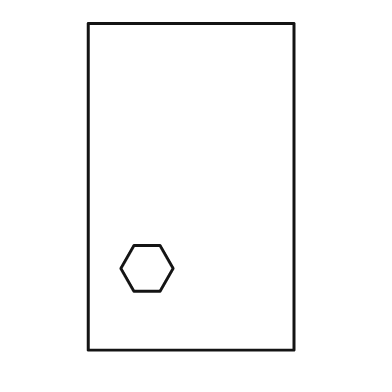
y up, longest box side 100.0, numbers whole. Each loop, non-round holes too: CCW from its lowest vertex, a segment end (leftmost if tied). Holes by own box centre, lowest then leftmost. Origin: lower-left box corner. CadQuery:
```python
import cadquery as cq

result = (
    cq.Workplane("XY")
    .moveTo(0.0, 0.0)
    .lineTo(63.0, 0.0)
    .lineTo(63.0, 100.0)
    .lineTo(0.0, 100.0)
    .close()
    .moveTo(14.0, 18.0)
    .lineTo(22.0, 18.0)
    .lineTo(26.0, 25.0)
    .lineTo(22.0, 32.0)
    .lineTo(14.0, 32.0)
    .lineTo(10.0, 25.0)
    .close()
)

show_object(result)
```